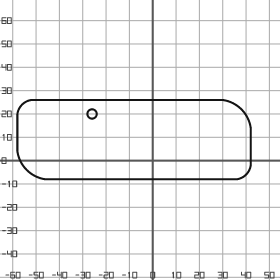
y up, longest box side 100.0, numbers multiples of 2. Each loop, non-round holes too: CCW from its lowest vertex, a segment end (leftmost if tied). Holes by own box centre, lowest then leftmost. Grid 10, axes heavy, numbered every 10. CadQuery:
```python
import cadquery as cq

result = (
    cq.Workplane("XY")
    .moveTo(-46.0, -8.0)
    .lineTo(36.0, -8.0)
    .threePointArc((40.0, -6.0), (42.0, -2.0))
    .lineTo(42.0, 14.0)
    .threePointArc((38.0, 22.0), (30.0, 26.0))
    .lineTo(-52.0, 26.0)
    .threePointArc((-56.0, 24.0), (-58.0, 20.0))
    .lineTo(-58.0, 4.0)
    .threePointArc((-54.0, -4.0), (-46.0, -8.0))
    .close()
    .moveTo(-26.0, 20.0)
    .circle(2.0)
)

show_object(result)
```